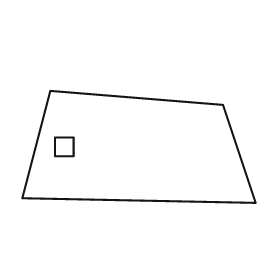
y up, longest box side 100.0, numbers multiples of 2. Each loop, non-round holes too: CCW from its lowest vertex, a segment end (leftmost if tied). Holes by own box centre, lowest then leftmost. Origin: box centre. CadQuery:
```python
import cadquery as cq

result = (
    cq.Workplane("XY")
    .moveTo(50.0, -24.0)
    .lineTo(36.0, 18.0)
    .lineTo(-38.0, 24.0)
    .lineTo(-50.0, -22.0)
    .close()
    .moveTo(-36.0, -4.0)
    .lineTo(-28.0, -4.0)
    .lineTo(-28.0, 4.0)
    .lineTo(-36.0, 4.0)
    .close()
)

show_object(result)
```